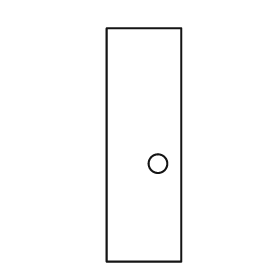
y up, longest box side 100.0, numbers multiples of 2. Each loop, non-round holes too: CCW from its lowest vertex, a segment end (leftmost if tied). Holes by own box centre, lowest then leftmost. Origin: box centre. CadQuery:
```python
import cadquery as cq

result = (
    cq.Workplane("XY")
    .moveTo(-16.0, -50.0)
    .lineTo(16.0, -50.0)
    .lineTo(16.0, 50.0)
    .lineTo(-16.0, 50.0)
    .close()
    .moveTo(6.0, -8.0)
    .circle(4.0)
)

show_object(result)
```